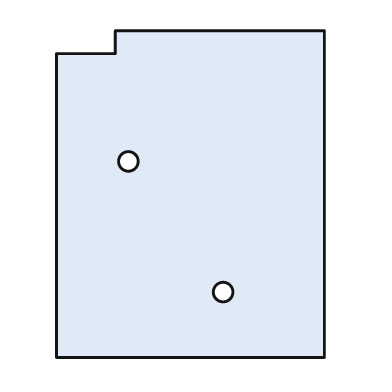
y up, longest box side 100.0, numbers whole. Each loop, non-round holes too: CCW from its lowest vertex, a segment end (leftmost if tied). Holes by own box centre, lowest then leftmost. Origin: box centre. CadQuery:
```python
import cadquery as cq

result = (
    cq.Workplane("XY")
    .moveTo(-41.0, -50.0)
    .lineTo(41.0, -50.0)
    .lineTo(41.0, 50.0)
    .lineTo(-23.0, 50.0)
    .lineTo(-23.0, 43.0)
    .lineTo(-41.0, 43.0)
    .close()
    .moveTo(10.0, -30.0)
    .circle(3.0)
    .moveTo(-19.0, 10.0)
    .circle(3.0)
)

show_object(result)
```